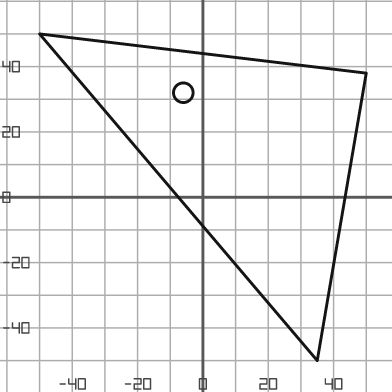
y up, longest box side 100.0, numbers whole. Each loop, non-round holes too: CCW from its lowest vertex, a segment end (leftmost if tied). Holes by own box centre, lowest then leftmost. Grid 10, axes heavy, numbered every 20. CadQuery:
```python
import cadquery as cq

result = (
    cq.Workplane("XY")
    .moveTo(35.0, -50.0)
    .lineTo(50.0, 38.0)
    .lineTo(-50.0, 50.0)
    .close()
    .moveTo(-6.0, 32.0)
    .circle(3.0)
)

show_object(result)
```